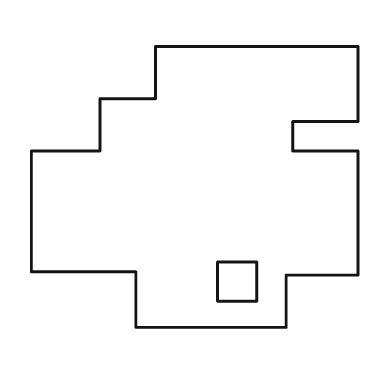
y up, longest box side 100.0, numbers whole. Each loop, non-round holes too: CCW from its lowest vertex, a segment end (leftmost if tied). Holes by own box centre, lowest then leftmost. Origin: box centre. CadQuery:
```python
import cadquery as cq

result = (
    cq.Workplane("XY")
    .moveTo(-18.0, -43.0)
    .lineTo(28.0, -43.0)
    .lineTo(28.0, -27.0)
    .lineTo(50.0, -27.0)
    .lineTo(50.0, 11.0)
    .lineTo(30.0, 11.0)
    .lineTo(30.0, 20.0)
    .lineTo(50.0, 20.0)
    .lineTo(50.0, 43.0)
    .lineTo(-12.0, 43.0)
    .lineTo(-12.0, 27.0)
    .lineTo(-29.0, 27.0)
    .lineTo(-29.0, 11.0)
    .lineTo(-50.0, 11.0)
    .lineTo(-50.0, -26.0)
    .lineTo(-18.0, -26.0)
    .close()
    .moveTo(7.0, -35.0)
    .lineTo(19.0, -35.0)
    .lineTo(19.0, -23.0)
    .lineTo(7.0, -23.0)
    .close()
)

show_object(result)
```